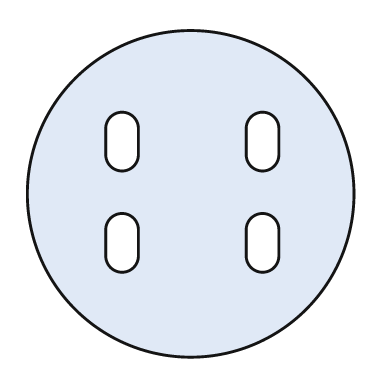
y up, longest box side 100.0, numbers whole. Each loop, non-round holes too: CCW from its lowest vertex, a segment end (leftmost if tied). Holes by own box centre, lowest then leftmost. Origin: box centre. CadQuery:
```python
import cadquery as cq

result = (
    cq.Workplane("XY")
    .moveTo(0.0, 0.0)
    .circle(50.0)
    .moveTo(-26.0, -19.0)
    .threePointArc((-21.0, -24.0), (-16.0, -19.0))
    .lineTo(-16.0, -11.0)
    .threePointArc((-21.0, -6.0), (-26.0, -11.0))
    .close()
    .moveTo(17.0, -19.0)
    .threePointArc((22.0, -24.0), (27.0, -19.0))
    .lineTo(27.0, -11.0)
    .threePointArc((22.0, -6.0), (17.0, -11.0))
    .close()
    .moveTo(-26.0, 12.0)
    .threePointArc((-21.0, 7.0), (-16.0, 12.0))
    .lineTo(-16.0, 20.0)
    .threePointArc((-21.0, 25.0), (-26.0, 20.0))
    .close()
    .moveTo(17.0, 12.0)
    .threePointArc((22.0, 7.0), (27.0, 12.0))
    .lineTo(27.0, 20.0)
    .threePointArc((22.0, 25.0), (17.0, 20.0))
    .close()
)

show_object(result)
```